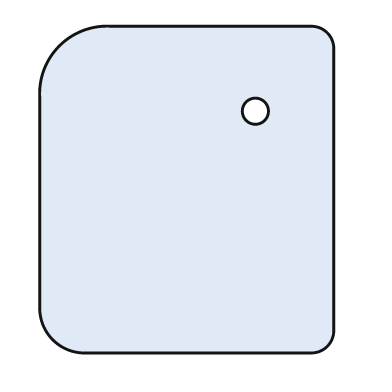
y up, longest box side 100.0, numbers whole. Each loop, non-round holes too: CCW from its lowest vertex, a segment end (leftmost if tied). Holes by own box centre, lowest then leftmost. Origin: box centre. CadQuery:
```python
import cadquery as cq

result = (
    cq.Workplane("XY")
    .moveTo(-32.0, -50.0)
    .lineTo(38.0, -50.0)
    .threePointArc((43.0, -48.0), (45.0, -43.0))
    .lineTo(45.0, 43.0)
    .threePointArc((43.0, 48.0), (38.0, 50.0))
    .lineTo(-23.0, 50.0)
    .threePointArc((-39.0, 44.0), (-45.0, 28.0))
    .lineTo(-45.0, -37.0)
    .threePointArc((-41.0, -46.0), (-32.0, -50.0))
    .close()
    .moveTo(21.0, 24.0)
    .circle(4.0)
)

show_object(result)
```